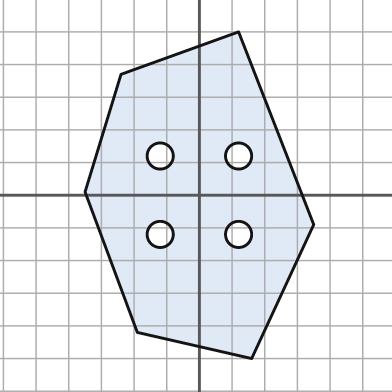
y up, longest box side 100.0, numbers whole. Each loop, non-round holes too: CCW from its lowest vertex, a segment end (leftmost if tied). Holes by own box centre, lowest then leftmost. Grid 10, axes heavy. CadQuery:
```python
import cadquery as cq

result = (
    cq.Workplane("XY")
    .moveTo(16.0, -50.0)
    .lineTo(35.0, -9.0)
    .lineTo(12.0, 50.0)
    .lineTo(-24.0, 37.0)
    .lineTo(-35.0, 1.0)
    .lineTo(-19.0, -42.0)
    .close()
    .moveTo(-12.0, -12.0)
    .circle(4.0)
    .moveTo(12.0, -12.0)
    .circle(4.0)
    .moveTo(-12.0, 12.0)
    .circle(4.0)
    .moveTo(12.0, 12.0)
    .circle(4.0)
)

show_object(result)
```